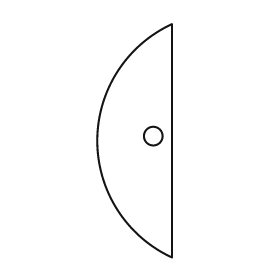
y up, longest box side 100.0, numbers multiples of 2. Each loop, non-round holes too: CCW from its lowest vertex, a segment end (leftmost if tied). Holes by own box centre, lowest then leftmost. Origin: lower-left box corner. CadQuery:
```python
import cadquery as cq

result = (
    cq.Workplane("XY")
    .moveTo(32.0, 0.0)
    .lineTo(32.0, 100.0)
    .threePointArc((0.0, 50.0), (32.0, 0.0))
    .close()
    .moveTo(24.0, 52.0)
    .circle(4.0)
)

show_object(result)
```